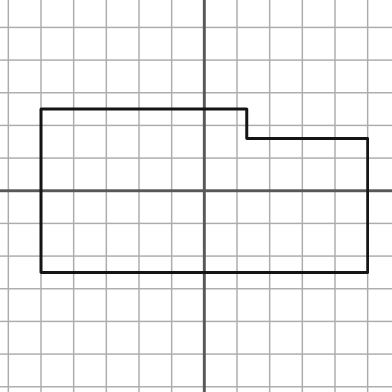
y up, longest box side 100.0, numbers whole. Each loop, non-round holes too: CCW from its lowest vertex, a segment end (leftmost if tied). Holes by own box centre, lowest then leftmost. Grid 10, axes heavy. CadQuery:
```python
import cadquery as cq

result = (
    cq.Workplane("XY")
    .moveTo(-50.0, -25.0)
    .lineTo(50.0, -25.0)
    .lineTo(50.0, 16.0)
    .lineTo(13.0, 16.0)
    .lineTo(13.0, 25.0)
    .lineTo(-50.0, 25.0)
    .close()
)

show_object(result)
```